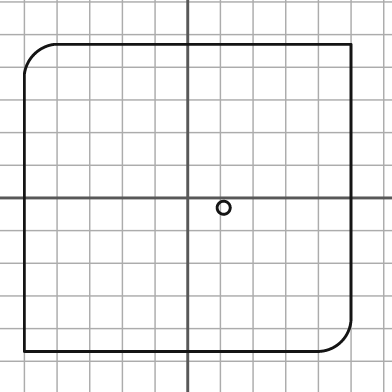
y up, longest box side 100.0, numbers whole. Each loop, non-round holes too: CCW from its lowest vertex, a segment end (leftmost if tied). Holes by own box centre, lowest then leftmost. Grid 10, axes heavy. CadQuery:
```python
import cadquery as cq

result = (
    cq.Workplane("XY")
    .moveTo(-50.0, -47.0)
    .lineTo(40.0, -47.0)
    .threePointArc((47.0, -44.0), (50.0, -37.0))
    .lineTo(50.0, 47.0)
    .lineTo(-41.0, 47.0)
    .threePointArc((-47.0, 44.0), (-50.0, 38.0))
    .close()
    .moveTo(11.0, -3.0)
    .circle(2.0)
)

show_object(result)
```